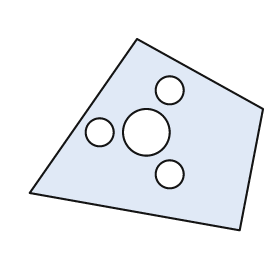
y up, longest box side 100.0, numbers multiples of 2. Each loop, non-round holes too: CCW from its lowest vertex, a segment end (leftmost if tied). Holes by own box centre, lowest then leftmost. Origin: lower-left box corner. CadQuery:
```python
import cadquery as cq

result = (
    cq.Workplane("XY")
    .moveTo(90.0, 0.0)
    .lineTo(100.0, 52.0)
    .lineTo(46.0, 82.0)
    .lineTo(0.0, 16.0)
    .close()
    .moveTo(60.0, 24.0)
    .circle(6.0)
    .moveTo(30.0, 42.0)
    .circle(6.0)
    .moveTo(50.0, 42.0)
    .circle(10.0)
    .moveTo(60.0, 60.0)
    .circle(6.0)
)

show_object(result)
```